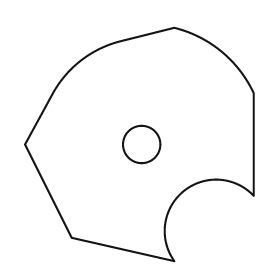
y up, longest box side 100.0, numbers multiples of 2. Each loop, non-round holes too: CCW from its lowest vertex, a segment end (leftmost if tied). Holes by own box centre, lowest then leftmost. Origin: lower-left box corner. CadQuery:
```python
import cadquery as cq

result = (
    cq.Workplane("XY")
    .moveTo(64.0, 0.0)
    .threePointArc((68.0, 30.0), (98.0, 28.0))
    .lineTo(98.0, 72.0)
    .threePointArc((84.0, 90.0), (64.0, 100.0))
    .lineTo(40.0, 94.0)
    .threePointArc((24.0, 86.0), (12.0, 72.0))
    .lineTo(0.0, 50.0)
    .lineTo(20.0, 10.0)
    .close()
    .moveTo(50.0, 50.0)
    .circle(8.0)
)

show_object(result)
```